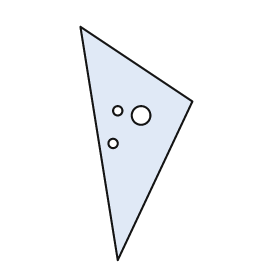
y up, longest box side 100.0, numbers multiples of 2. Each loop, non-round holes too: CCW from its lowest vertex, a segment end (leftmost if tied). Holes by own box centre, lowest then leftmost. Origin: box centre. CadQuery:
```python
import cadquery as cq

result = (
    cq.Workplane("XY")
    .moveTo(-8.0, -50.0)
    .lineTo(24.0, 18.0)
    .lineTo(-24.0, 50.0)
    .close()
    .moveTo(-10.0, 0.0)
    .circle(2.0)
    .moveTo(2.0, 12.0)
    .circle(4.0)
    .moveTo(-8.0, 14.0)
    .circle(2.0)
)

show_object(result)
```